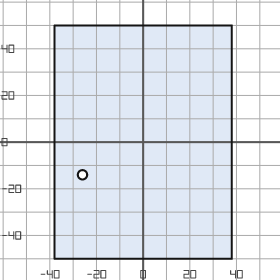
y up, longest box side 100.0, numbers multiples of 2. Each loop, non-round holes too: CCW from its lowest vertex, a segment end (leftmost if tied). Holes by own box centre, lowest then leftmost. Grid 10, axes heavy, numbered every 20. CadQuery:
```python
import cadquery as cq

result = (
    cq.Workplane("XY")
    .moveTo(-38.0, -50.0)
    .lineTo(38.0, -50.0)
    .lineTo(38.0, 50.0)
    .lineTo(-38.0, 50.0)
    .close()
    .moveTo(-26.0, -14.0)
    .circle(2.0)
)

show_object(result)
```